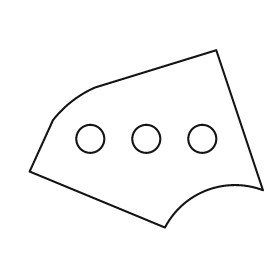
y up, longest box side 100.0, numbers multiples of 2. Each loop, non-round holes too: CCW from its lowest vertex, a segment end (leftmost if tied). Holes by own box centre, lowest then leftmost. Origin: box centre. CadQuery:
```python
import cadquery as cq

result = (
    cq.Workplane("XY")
    .moveTo(8.0, -38.0)
    .threePointArc((26.0, -22.0), (50.0, -22.0))
    .lineTo(30.0, 38.0)
    .lineTo(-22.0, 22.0)
    .threePointArc((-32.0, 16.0), (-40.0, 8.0))
    .lineTo(-50.0, -14.0)
    .close()
    .moveTo(-24.0, 0.0)
    .circle(6.0)
    .moveTo(0.0, 0.0)
    .circle(6.0)
    .moveTo(24.0, 0.0)
    .circle(6.0)
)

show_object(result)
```